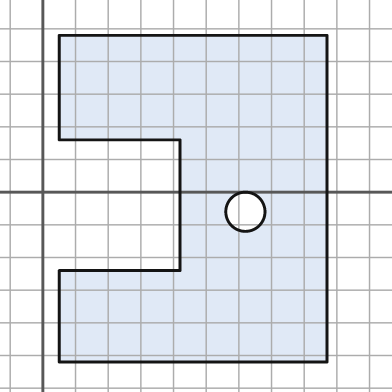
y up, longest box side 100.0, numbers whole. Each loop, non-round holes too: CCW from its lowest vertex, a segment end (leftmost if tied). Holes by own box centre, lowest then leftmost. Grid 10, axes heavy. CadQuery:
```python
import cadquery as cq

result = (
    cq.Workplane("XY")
    .moveTo(5.0, -52.0)
    .lineTo(87.0, -52.0)
    .lineTo(87.0, 48.0)
    .lineTo(5.0, 48.0)
    .lineTo(5.0, 16.0)
    .lineTo(42.0, 16.0)
    .lineTo(42.0, -24.0)
    .lineTo(5.0, -24.0)
    .close()
    .moveTo(62.0, -6.0)
    .circle(6.0)
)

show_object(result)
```